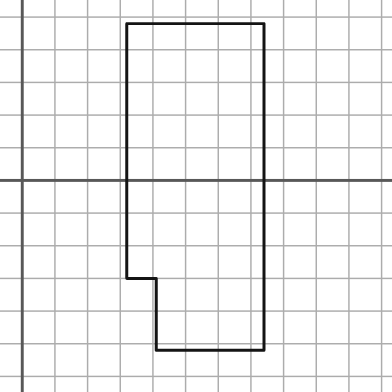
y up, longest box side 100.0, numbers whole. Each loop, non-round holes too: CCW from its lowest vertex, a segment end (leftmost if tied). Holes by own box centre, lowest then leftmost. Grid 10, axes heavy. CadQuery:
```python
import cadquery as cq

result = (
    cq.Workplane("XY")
    .moveTo(41.0, -52.0)
    .lineTo(74.0, -52.0)
    .lineTo(74.0, 48.0)
    .lineTo(32.0, 48.0)
    .lineTo(32.0, -30.0)
    .lineTo(41.0, -30.0)
    .close()
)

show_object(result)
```